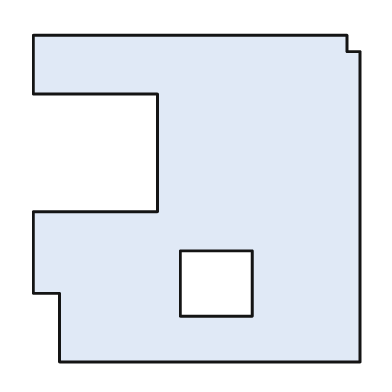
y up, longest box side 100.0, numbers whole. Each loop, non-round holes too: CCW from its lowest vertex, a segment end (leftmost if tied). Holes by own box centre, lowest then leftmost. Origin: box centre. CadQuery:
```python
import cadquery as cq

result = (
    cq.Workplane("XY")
    .moveTo(-42.0, -50.0)
    .lineTo(50.0, -50.0)
    .lineTo(50.0, 45.0)
    .lineTo(46.0, 45.0)
    .lineTo(46.0, 50.0)
    .lineTo(-50.0, 50.0)
    .lineTo(-50.0, 32.0)
    .lineTo(-12.0, 32.0)
    .lineTo(-12.0, -4.0)
    .lineTo(-50.0, -4.0)
    .lineTo(-50.0, -29.0)
    .lineTo(-42.0, -29.0)
    .close()
    .moveTo(-5.0, -36.0)
    .lineTo(17.0, -36.0)
    .lineTo(17.0, -16.0)
    .lineTo(-5.0, -16.0)
    .close()
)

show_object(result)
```